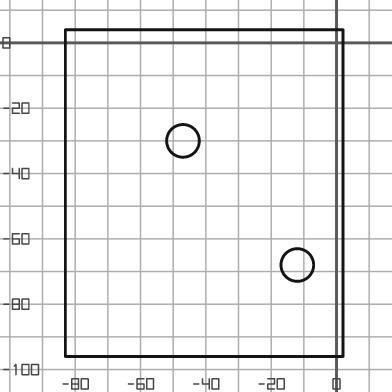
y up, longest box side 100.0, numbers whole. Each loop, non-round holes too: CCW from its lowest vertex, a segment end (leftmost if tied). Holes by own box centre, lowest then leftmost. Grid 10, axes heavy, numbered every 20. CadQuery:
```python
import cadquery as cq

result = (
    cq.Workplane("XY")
    .moveTo(-83.0, -96.0)
    .lineTo(2.0, -96.0)
    .lineTo(2.0, 4.0)
    .lineTo(-83.0, 4.0)
    .close()
    .moveTo(-12.0, -68.0)
    .circle(5.0)
    .moveTo(-47.0, -30.0)
    .circle(5.0)
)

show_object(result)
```